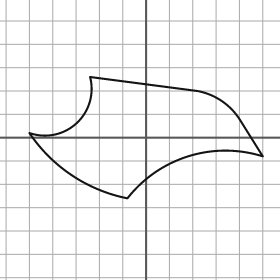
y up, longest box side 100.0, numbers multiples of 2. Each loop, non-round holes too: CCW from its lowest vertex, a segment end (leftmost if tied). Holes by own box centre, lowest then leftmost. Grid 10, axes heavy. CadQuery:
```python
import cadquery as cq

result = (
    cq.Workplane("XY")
    .moveTo(-8.0, -26.0)
    .threePointArc((18.0, -8.0), (50.0, -8.0))
    .lineTo(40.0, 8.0)
    .threePointArc((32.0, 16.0), (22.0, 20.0))
    .lineTo(-24.0, 26.0)
    .threePointArc((-30.0, 6.0), (-50.0, 2.0))
    .threePointArc((-32.0, -16.0), (-8.0, -26.0))
    .close()
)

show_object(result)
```